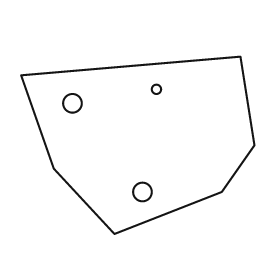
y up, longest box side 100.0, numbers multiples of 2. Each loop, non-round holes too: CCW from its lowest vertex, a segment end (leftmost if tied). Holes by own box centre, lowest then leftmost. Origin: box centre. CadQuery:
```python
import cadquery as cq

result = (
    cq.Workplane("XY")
    .moveTo(-10.0, -38.0)
    .lineTo(36.0, -20.0)
    .lineTo(50.0, 0.0)
    .lineTo(44.0, 38.0)
    .lineTo(-50.0, 30.0)
    .lineTo(-36.0, -10.0)
    .close()
    .moveTo(2.0, -20.0)
    .circle(4.0)
    .moveTo(-28.0, 18.0)
    .circle(4.0)
    .moveTo(8.0, 24.0)
    .circle(2.0)
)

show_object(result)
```